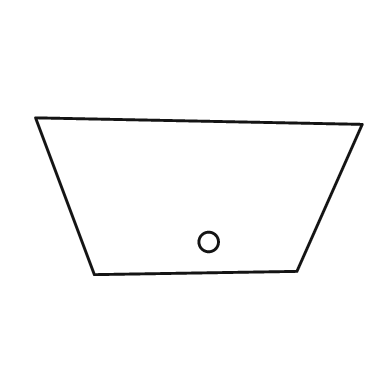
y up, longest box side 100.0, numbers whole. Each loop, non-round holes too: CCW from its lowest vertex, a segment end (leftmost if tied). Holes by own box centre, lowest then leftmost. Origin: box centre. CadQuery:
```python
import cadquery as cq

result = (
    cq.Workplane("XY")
    .moveTo(-32.0, -24.0)
    .lineTo(30.0, -23.0)
    .lineTo(50.0, 22.0)
    .lineTo(-50.0, 24.0)
    .close()
    .moveTo(3.0, -14.0)
    .circle(3.0)
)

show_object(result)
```